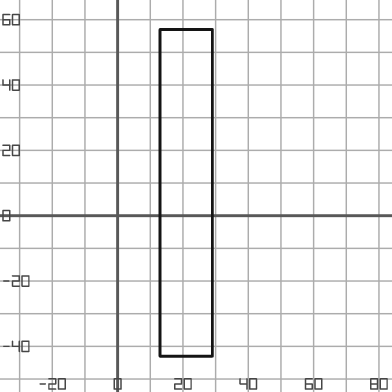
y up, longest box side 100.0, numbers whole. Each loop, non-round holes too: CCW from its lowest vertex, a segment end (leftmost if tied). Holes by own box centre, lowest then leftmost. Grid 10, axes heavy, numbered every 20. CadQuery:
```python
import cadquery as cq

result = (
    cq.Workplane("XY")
    .moveTo(13.0, -43.0)
    .lineTo(29.0, -43.0)
    .lineTo(29.0, 57.0)
    .lineTo(13.0, 57.0)
    .close()
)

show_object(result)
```